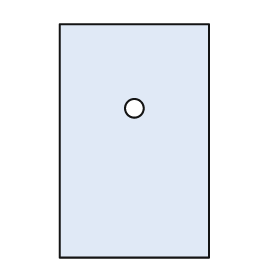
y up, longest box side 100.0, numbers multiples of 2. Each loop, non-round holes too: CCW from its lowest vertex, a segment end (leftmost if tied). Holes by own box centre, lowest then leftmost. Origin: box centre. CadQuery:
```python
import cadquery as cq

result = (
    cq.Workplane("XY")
    .moveTo(-32.0, -50.0)
    .lineTo(32.0, -50.0)
    .lineTo(32.0, 50.0)
    .lineTo(-32.0, 50.0)
    .close()
    .moveTo(0.0, 14.0)
    .circle(4.0)
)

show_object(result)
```